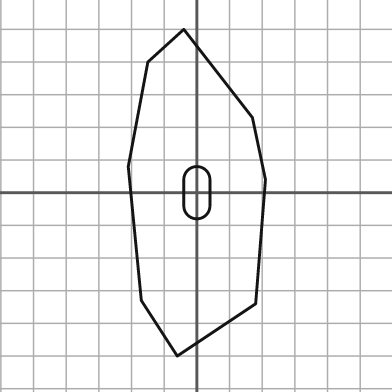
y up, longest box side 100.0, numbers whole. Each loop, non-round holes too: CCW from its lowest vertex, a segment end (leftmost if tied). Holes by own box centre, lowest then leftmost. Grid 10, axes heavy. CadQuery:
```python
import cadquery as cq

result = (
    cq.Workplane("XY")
    .moveTo(-6.0, -50.0)
    .lineTo(18.0, -34.0)
    .lineTo(21.0, 4.0)
    .lineTo(17.0, 23.0)
    .lineTo(-4.0, 50.0)
    .lineTo(-15.0, 40.0)
    .lineTo(-21.0, 8.0)
    .lineTo(-17.0, -33.0)
    .close()
    .moveTo(-4.0, -4.0)
    .threePointArc((0.0, -8.0), (4.0, -4.0))
    .lineTo(4.0, 4.0)
    .threePointArc((0.0, 8.0), (-4.0, 4.0))
    .close()
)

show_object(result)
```